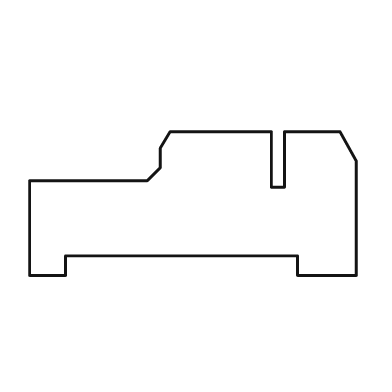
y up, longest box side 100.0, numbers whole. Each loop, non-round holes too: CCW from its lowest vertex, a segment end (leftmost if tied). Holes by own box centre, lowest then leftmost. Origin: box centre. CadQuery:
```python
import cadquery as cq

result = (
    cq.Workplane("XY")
    .moveTo(-50.0, -22.0)
    .lineTo(-39.0, -22.0)
    .lineTo(-39.0, -16.0)
    .lineTo(32.0, -16.0)
    .lineTo(32.0, -22.0)
    .lineTo(50.0, -22.0)
    .lineTo(50.0, 13.0)
    .lineTo(45.0, 22.0)
    .lineTo(28.0, 22.0)
    .lineTo(28.0, 5.0)
    .lineTo(24.0, 5.0)
    .lineTo(24.0, 22.0)
    .lineTo(-7.0, 22.0)
    .lineTo(-10.0, 17.0)
    .lineTo(-10.0, 11.0)
    .lineTo(-14.0, 7.0)
    .lineTo(-50.0, 7.0)
    .close()
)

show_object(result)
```